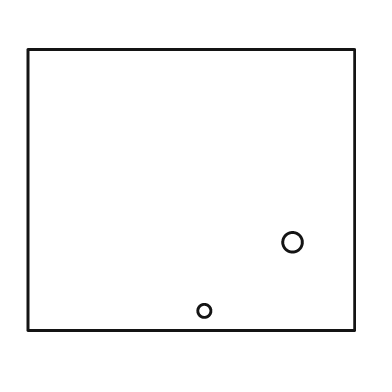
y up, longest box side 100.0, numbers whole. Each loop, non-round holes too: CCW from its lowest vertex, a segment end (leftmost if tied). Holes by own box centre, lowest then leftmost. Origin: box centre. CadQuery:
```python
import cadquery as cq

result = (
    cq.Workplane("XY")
    .moveTo(-50.0, -43.0)
    .lineTo(50.0, -43.0)
    .lineTo(50.0, 43.0)
    .lineTo(-50.0, 43.0)
    .close()
    .moveTo(4.0, -37.0)
    .circle(2.0)
    .moveTo(31.0, -16.0)
    .circle(3.0)
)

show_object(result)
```